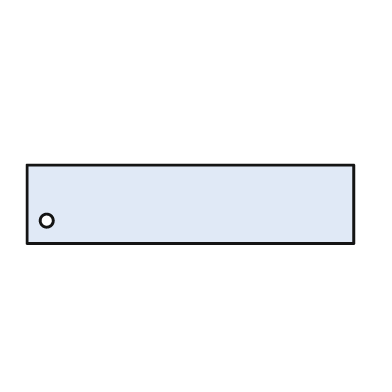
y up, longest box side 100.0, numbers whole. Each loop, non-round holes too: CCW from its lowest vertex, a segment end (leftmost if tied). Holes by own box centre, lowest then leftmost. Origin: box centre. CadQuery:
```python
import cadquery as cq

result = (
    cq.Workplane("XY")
    .moveTo(-50.0, -12.0)
    .lineTo(50.0, -12.0)
    .lineTo(50.0, 12.0)
    .lineTo(-50.0, 12.0)
    .close()
    .moveTo(-44.0, -5.0)
    .circle(2.0)
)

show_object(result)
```